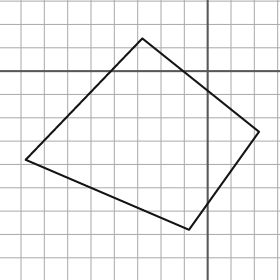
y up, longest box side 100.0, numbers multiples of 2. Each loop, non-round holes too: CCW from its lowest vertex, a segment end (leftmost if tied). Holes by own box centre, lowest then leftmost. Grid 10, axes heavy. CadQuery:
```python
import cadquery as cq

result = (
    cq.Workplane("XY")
    .moveTo(-8.0, -68.0)
    .lineTo(22.0, -26.0)
    .lineTo(-28.0, 14.0)
    .lineTo(-78.0, -38.0)
    .close()
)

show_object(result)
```